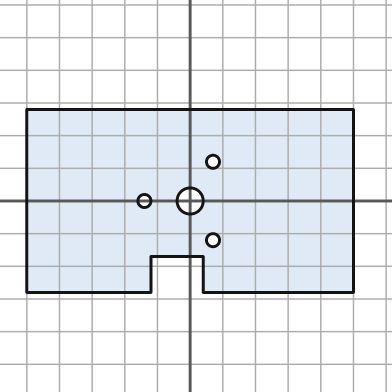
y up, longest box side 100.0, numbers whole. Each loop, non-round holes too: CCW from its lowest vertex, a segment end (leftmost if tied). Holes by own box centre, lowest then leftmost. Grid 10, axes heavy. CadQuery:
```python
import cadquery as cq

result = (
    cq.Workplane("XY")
    .moveTo(-50.0, -28.0)
    .lineTo(-12.0, -28.0)
    .lineTo(-12.0, -17.0)
    .lineTo(4.0, -17.0)
    .lineTo(4.0, -28.0)
    .lineTo(50.0, -28.0)
    .lineTo(50.0, 28.0)
    .lineTo(-50.0, 28.0)
    .close()
    .moveTo(7.0, -12.0)
    .circle(2.0)
    .moveTo(-14.0, 0.0)
    .circle(2.0)
    .moveTo(0.0, 0.0)
    .circle(4.0)
    .moveTo(7.0, 12.0)
    .circle(2.0)
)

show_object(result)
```